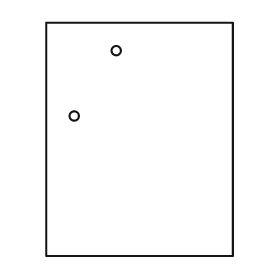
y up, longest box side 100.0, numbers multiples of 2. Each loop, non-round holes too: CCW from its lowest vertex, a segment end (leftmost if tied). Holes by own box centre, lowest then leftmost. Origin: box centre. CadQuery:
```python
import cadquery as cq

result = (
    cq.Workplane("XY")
    .moveTo(-40.0, -50.0)
    .lineTo(40.0, -50.0)
    .lineTo(40.0, 50.0)
    .lineTo(-40.0, 50.0)
    .close()
    .moveTo(-28.0, 10.0)
    .circle(2.0)
    .moveTo(-10.0, 38.0)
    .circle(2.0)
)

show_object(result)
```